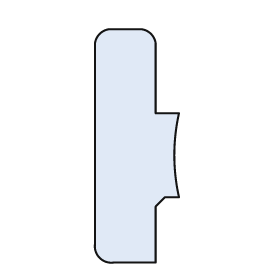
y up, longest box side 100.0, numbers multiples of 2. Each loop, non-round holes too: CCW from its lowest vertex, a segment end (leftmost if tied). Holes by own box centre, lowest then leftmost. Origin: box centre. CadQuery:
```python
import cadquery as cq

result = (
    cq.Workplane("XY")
    .moveTo(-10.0, -50.0)
    .lineTo(8.0, -50.0)
    .lineTo(8.0, -26.0)
    .lineTo(12.0, -22.0)
    .lineTo(18.0, -22.0)
    .threePointArc((16.0, -4.0), (18.0, 14.0))
    .lineTo(8.0, 14.0)
    .lineTo(8.0, 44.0)
    .threePointArc((6.0, 48.0), (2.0, 50.0))
    .lineTo(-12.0, 50.0)
    .threePointArc((-16.0, 48.0), (-18.0, 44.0))
    .lineTo(-18.0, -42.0)
    .threePointArc((-16.0, -48.0), (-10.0, -50.0))
    .close()
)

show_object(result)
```